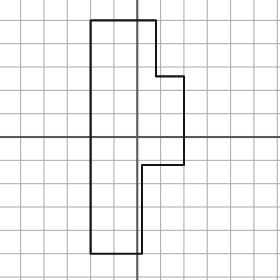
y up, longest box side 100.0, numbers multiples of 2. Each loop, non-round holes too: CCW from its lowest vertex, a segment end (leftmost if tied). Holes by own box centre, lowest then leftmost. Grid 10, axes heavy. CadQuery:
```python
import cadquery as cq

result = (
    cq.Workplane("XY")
    .moveTo(-20.0, -50.0)
    .lineTo(2.0, -50.0)
    .lineTo(2.0, -12.0)
    .lineTo(20.0, -12.0)
    .lineTo(20.0, 26.0)
    .lineTo(8.0, 26.0)
    .lineTo(8.0, 50.0)
    .lineTo(-20.0, 50.0)
    .close()
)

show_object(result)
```